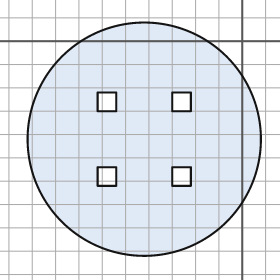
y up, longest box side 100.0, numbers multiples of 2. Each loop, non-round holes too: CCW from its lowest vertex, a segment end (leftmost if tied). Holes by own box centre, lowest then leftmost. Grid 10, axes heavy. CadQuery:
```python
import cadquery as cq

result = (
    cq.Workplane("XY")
    .moveTo(-42.0, -42.0)
    .circle(50.0)
    .moveTo(-62.0, -62.0)
    .lineTo(-54.0, -62.0)
    .lineTo(-54.0, -54.0)
    .lineTo(-62.0, -54.0)
    .close()
    .moveTo(-30.0, -62.0)
    .lineTo(-22.0, -62.0)
    .lineTo(-22.0, -54.0)
    .lineTo(-30.0, -54.0)
    .close()
    .moveTo(-62.0, -30.0)
    .lineTo(-54.0, -30.0)
    .lineTo(-54.0, -22.0)
    .lineTo(-62.0, -22.0)
    .close()
    .moveTo(-30.0, -30.0)
    .lineTo(-22.0, -30.0)
    .lineTo(-22.0, -22.0)
    .lineTo(-30.0, -22.0)
    .close()
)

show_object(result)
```